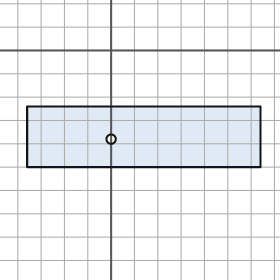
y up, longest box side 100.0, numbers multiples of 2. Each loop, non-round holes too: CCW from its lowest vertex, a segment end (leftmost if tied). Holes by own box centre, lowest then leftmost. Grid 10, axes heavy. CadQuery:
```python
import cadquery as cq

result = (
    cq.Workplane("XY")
    .moveTo(-36.0, -50.0)
    .lineTo(64.0, -50.0)
    .lineTo(64.0, -24.0)
    .lineTo(-36.0, -24.0)
    .close()
    .moveTo(0.0, -38.0)
    .circle(2.0)
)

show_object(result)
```